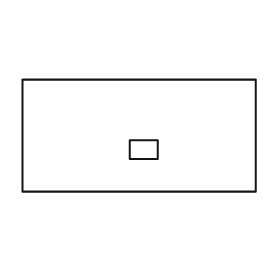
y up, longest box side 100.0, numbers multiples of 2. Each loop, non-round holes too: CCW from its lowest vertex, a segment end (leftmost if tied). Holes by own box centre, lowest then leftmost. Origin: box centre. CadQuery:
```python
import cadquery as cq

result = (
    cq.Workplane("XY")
    .moveTo(-50.0, -24.0)
    .lineTo(50.0, -24.0)
    .lineTo(50.0, 24.0)
    .lineTo(-50.0, 24.0)
    .close()
    .moveTo(-4.0, -10.0)
    .lineTo(8.0, -10.0)
    .lineTo(8.0, -2.0)
    .lineTo(-4.0, -2.0)
    .close()
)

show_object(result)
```